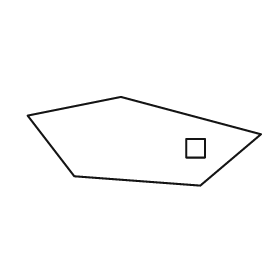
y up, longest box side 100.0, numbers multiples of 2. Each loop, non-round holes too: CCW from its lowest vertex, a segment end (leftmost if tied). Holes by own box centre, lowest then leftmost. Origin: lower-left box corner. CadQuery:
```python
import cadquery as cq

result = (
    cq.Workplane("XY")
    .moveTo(74.0, 0.0)
    .lineTo(100.0, 22.0)
    .lineTo(40.0, 38.0)
    .lineTo(0.0, 30.0)
    .lineTo(20.0, 4.0)
    .close()
    .moveTo(68.0, 12.0)
    .lineTo(76.0, 12.0)
    .lineTo(76.0, 20.0)
    .lineTo(68.0, 20.0)
    .close()
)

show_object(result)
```